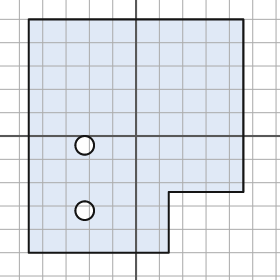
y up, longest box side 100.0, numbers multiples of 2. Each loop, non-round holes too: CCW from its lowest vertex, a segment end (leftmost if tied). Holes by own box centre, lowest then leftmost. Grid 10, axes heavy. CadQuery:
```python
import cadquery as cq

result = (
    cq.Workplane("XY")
    .moveTo(-46.0, -50.0)
    .lineTo(14.0, -50.0)
    .lineTo(14.0, -24.0)
    .lineTo(46.0, -24.0)
    .lineTo(46.0, 50.0)
    .lineTo(-46.0, 50.0)
    .close()
    .moveTo(-22.0, -32.0)
    .circle(4.0)
    .moveTo(-22.0, -4.0)
    .circle(4.0)
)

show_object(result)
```